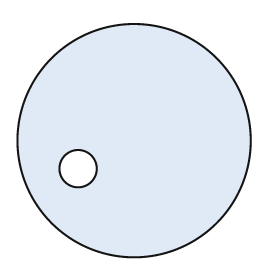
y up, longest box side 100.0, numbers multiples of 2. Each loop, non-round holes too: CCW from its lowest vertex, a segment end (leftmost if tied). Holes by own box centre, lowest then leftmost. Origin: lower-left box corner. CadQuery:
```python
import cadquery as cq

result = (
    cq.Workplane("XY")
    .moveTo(50.0, 50.0)
    .circle(50.0)
    .moveTo(26.0, 38.0)
    .circle(8.0)
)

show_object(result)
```